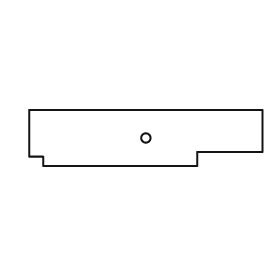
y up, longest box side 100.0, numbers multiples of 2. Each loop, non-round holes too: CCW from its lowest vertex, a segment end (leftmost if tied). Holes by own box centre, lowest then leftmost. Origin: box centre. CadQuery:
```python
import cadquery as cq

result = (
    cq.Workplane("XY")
    .moveTo(-44.0, -12.0)
    .lineTo(22.0, -12.0)
    .lineTo(22.0, -6.0)
    .lineTo(50.0, -6.0)
    .lineTo(50.0, 12.0)
    .lineTo(-50.0, 12.0)
    .lineTo(-50.0, -8.0)
    .lineTo(-44.0, -8.0)
    .close()
    .moveTo(0.0, 0.0)
    .circle(2.0)
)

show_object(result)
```